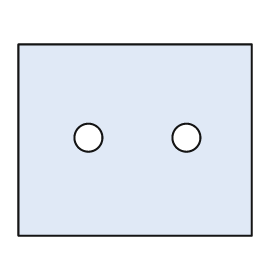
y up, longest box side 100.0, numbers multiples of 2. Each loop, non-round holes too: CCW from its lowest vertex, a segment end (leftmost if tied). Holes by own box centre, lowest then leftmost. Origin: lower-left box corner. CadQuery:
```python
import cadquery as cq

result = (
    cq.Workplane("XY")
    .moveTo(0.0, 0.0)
    .lineTo(100.0, 0.0)
    .lineTo(100.0, 82.0)
    .lineTo(0.0, 82.0)
    .close()
    .moveTo(30.0, 42.0)
    .circle(6.0)
    .moveTo(72.0, 42.0)
    .circle(6.0)
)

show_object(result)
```